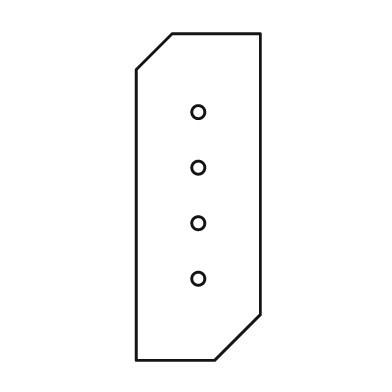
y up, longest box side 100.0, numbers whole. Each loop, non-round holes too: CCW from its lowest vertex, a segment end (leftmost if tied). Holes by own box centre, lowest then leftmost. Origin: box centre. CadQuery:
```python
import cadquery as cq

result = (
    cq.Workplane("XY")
    .moveTo(-19.0, -50.0)
    .lineTo(5.0, -50.0)
    .lineTo(19.0, -36.0)
    .lineTo(19.0, 50.0)
    .lineTo(-8.0, 50.0)
    .lineTo(-19.0, 39.0)
    .close()
    .moveTo(0.0, -25.0)
    .circle(2.0)
    .moveTo(0.0, -8.0)
    .circle(2.0)
    .moveTo(0.0, 9.0)
    .circle(2.0)
    .moveTo(0.0, 26.0)
    .circle(2.0)
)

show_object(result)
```